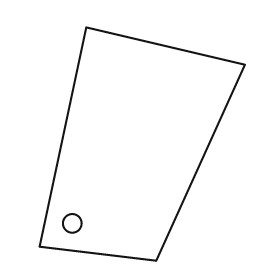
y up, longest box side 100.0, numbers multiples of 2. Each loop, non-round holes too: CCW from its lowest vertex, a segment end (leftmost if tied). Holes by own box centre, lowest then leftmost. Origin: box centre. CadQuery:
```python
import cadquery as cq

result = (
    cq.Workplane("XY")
    .moveTo(6.0, -50.0)
    .lineTo(44.0, 34.0)
    .lineTo(-24.0, 50.0)
    .lineTo(-44.0, -44.0)
    .close()
    .moveTo(-30.0, -34.0)
    .circle(4.0)
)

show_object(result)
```